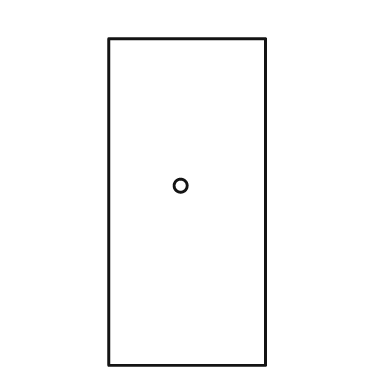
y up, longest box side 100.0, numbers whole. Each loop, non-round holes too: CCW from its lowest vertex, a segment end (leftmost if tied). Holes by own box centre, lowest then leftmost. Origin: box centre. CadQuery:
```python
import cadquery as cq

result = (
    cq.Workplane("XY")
    .moveTo(-24.0, -50.0)
    .lineTo(24.0, -50.0)
    .lineTo(24.0, 50.0)
    .lineTo(-24.0, 50.0)
    .close()
    .moveTo(-2.0, 5.0)
    .circle(2.0)
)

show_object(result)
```